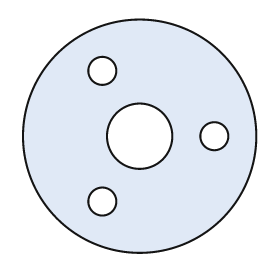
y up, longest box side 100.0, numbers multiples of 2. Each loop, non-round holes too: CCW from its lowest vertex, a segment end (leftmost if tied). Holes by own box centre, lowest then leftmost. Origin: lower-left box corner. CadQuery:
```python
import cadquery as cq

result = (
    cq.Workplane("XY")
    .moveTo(50.0, 50.0)
    .circle(50.0)
    .moveTo(34.0, 22.0)
    .circle(6.0)
    .moveTo(50.0, 50.0)
    .circle(14.0)
    .moveTo(82.0, 50.0)
    .circle(6.0)
    .moveTo(34.0, 78.0)
    .circle(6.0)
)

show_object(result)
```